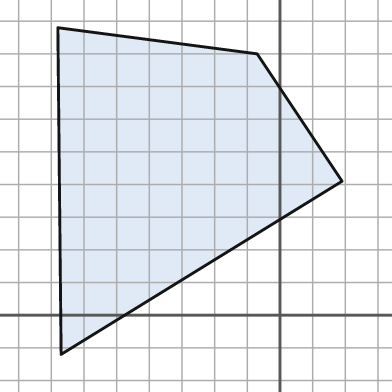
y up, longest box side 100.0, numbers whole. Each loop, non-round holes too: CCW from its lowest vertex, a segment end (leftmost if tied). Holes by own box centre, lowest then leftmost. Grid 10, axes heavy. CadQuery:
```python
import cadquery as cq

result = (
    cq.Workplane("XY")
    .moveTo(-67.0, -12.0)
    .lineTo(19.0, 41.0)
    .lineTo(-7.0, 80.0)
    .lineTo(-68.0, 88.0)
    .close()
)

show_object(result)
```